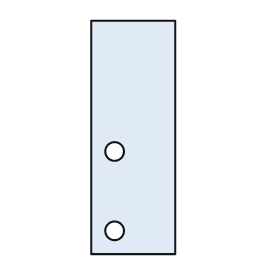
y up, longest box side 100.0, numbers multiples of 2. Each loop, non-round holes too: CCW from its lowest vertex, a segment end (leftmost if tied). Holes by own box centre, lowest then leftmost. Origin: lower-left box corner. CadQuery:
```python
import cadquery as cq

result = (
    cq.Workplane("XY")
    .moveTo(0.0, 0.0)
    .lineTo(36.0, 0.0)
    .lineTo(36.0, 100.0)
    .lineTo(0.0, 100.0)
    .close()
    .moveTo(10.0, 10.0)
    .circle(4.0)
    .moveTo(10.0, 44.0)
    .circle(4.0)
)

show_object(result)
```